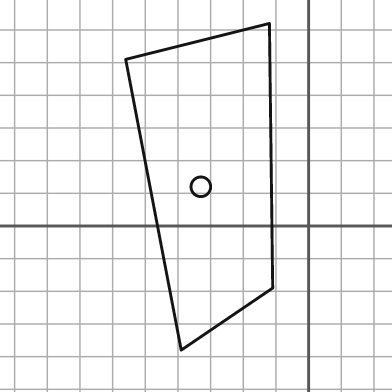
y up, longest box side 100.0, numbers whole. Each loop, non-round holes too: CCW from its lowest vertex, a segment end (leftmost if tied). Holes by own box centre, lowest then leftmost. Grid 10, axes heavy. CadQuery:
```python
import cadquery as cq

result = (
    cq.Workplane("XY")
    .moveTo(-39.0, -38.0)
    .lineTo(-11.0, -19.0)
    .lineTo(-12.0, 62.0)
    .lineTo(-56.0, 51.0)
    .close()
    .moveTo(-33.0, 12.0)
    .circle(3.0)
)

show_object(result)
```